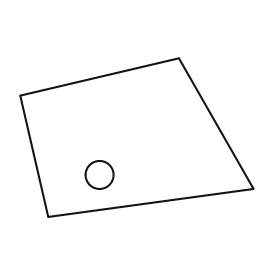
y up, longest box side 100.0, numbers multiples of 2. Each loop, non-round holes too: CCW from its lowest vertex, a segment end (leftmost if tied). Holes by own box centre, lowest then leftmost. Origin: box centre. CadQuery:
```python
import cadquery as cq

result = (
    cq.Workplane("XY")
    .moveTo(-38.0, -34.0)
    .lineTo(50.0, -22.0)
    .lineTo(18.0, 34.0)
    .lineTo(-50.0, 18.0)
    .close()
    .moveTo(-16.0, -16.0)
    .circle(6.0)
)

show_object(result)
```